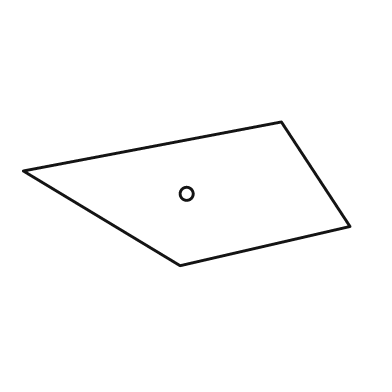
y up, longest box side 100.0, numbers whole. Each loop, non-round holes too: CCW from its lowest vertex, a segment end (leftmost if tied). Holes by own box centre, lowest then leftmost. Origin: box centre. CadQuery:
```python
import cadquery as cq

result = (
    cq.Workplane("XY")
    .moveTo(-2.0, -22.0)
    .lineTo(50.0, -10.0)
    .lineTo(29.0, 22.0)
    .lineTo(-50.0, 7.0)
    .close()
    .moveTo(0.0, 0.0)
    .circle(2.0)
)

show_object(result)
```